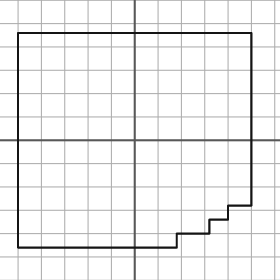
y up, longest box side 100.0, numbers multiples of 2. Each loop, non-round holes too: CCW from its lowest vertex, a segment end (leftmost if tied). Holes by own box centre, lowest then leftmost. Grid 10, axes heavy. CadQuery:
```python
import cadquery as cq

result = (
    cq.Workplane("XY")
    .moveTo(-50.0, -46.0)
    .lineTo(18.0, -46.0)
    .lineTo(18.0, -40.0)
    .lineTo(32.0, -40.0)
    .lineTo(32.0, -34.0)
    .lineTo(40.0, -34.0)
    .lineTo(40.0, -28.0)
    .lineTo(50.0, -28.0)
    .lineTo(50.0, 46.0)
    .lineTo(-50.0, 46.0)
    .close()
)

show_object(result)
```